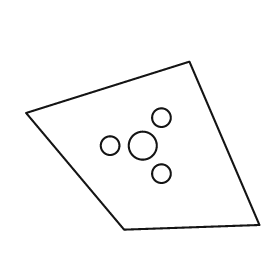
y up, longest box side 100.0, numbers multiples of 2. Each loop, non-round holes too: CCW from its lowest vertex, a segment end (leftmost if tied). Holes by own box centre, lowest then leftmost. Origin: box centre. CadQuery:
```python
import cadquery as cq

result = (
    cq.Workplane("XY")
    .moveTo(-8.0, -36.0)
    .lineTo(50.0, -34.0)
    .lineTo(20.0, 36.0)
    .lineTo(-50.0, 14.0)
    .close()
    .moveTo(8.0, -12.0)
    .circle(4.0)
    .moveTo(-14.0, 0.0)
    .circle(4.0)
    .moveTo(0.0, 0.0)
    .circle(6.0)
    .moveTo(8.0, 12.0)
    .circle(4.0)
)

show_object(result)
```